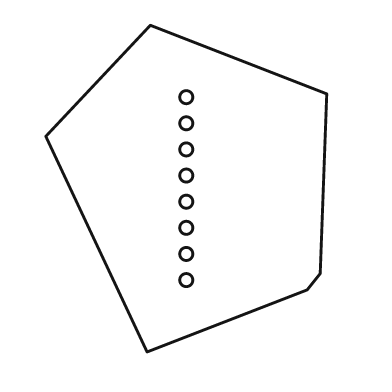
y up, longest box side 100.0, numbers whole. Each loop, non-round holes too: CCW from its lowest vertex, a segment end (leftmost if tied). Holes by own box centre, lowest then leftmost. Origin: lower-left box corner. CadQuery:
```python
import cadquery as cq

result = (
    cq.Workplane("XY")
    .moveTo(31.0, 0.0)
    .lineTo(80.0, 19.0)
    .lineTo(84.0, 24.0)
    .lineTo(86.0, 79.0)
    .lineTo(32.0, 100.0)
    .lineTo(0.0, 66.0)
    .close()
    .moveTo(43.0, 22.0)
    .circle(2.0)
    .moveTo(43.0, 30.0)
    .circle(2.0)
    .moveTo(43.0, 38.0)
    .circle(2.0)
    .moveTo(43.0, 46.0)
    .circle(2.0)
    .moveTo(43.0, 54.0)
    .circle(2.0)
    .moveTo(43.0, 62.0)
    .circle(2.0)
    .moveTo(43.0, 70.0)
    .circle(2.0)
    .moveTo(43.0, 78.0)
    .circle(2.0)
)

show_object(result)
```